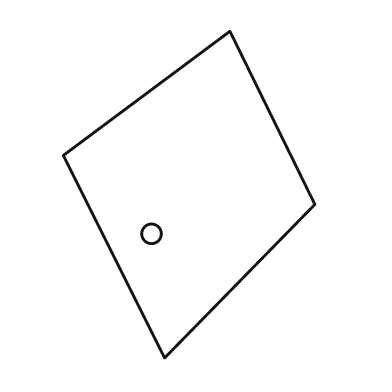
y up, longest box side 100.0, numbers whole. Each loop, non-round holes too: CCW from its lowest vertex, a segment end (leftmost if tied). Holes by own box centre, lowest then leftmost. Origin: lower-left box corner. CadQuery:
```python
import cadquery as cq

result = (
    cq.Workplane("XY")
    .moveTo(31.0, 0.0)
    .lineTo(77.0, 47.0)
    .lineTo(51.0, 100.0)
    .lineTo(0.0, 62.0)
    .close()
    .moveTo(27.0, 38.0)
    .circle(3.0)
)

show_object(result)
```